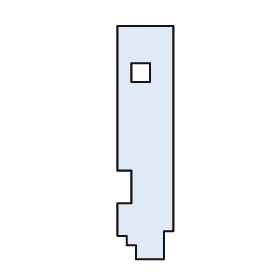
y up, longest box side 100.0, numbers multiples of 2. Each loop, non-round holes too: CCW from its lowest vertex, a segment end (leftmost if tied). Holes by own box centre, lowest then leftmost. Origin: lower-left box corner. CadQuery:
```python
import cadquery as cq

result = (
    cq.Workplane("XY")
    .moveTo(8.0, 0.0)
    .lineTo(20.0, 0.0)
    .lineTo(20.0, 12.0)
    .lineTo(24.0, 12.0)
    .lineTo(24.0, 100.0)
    .lineTo(0.0, 100.0)
    .lineTo(0.0, 38.0)
    .lineTo(6.0, 38.0)
    .lineTo(6.0, 24.0)
    .lineTo(0.0, 24.0)
    .lineTo(0.0, 10.0)
    .lineTo(4.0, 10.0)
    .lineTo(4.0, 6.0)
    .lineTo(8.0, 6.0)
    .close()
    .moveTo(6.0, 76.0)
    .lineTo(14.0, 76.0)
    .lineTo(14.0, 84.0)
    .lineTo(6.0, 84.0)
    .close()
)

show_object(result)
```